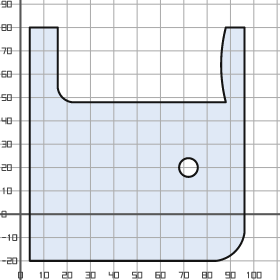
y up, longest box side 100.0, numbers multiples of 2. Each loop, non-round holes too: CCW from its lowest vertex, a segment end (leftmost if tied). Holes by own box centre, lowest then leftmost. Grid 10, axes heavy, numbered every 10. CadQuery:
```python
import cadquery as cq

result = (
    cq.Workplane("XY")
    .moveTo(4.0, -20.0)
    .lineTo(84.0, -20.0)
    .threePointArc((92.0, -16.0), (96.0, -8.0))
    .lineTo(96.0, 80.0)
    .lineTo(88.0, 80.0)
    .threePointArc((86.0, 64.0), (88.0, 48.0))
    .lineTo(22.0, 48.0)
    .threePointArc((18.0, 50.0), (16.0, 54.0))
    .lineTo(16.0, 80.0)
    .lineTo(4.0, 80.0)
    .close()
    .moveTo(72.0, 20.0)
    .circle(4.0)
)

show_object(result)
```